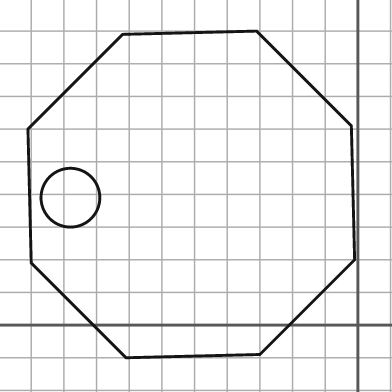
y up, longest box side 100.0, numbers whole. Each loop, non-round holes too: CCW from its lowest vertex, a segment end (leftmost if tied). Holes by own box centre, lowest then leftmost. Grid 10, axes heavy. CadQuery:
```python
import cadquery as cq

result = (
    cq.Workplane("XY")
    .moveTo(-71.0, -10.0)
    .lineTo(-30.0, -9.0)
    .lineTo(-1.0, 20.0)
    .lineTo(-2.0, 61.0)
    .lineTo(-31.0, 90.0)
    .lineTo(-72.0, 89.0)
    .lineTo(-101.0, 60.0)
    .lineTo(-100.0, 19.0)
    .close()
    .moveTo(-88.0, 39.0)
    .circle(9.0)
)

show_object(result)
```